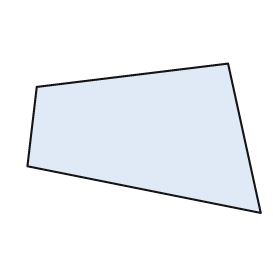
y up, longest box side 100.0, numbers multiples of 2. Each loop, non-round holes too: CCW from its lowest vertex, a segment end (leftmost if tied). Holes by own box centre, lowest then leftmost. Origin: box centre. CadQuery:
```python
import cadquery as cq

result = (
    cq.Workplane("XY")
    .moveTo(50.0, -32.0)
    .lineTo(36.0, 32.0)
    .lineTo(-46.0, 22.0)
    .lineTo(-50.0, -12.0)
    .close()
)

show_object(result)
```